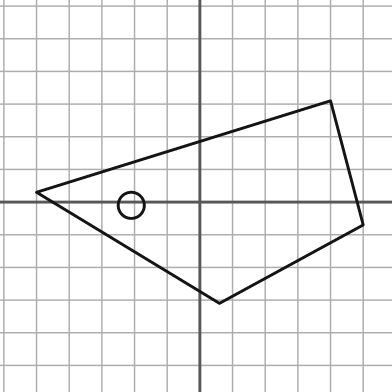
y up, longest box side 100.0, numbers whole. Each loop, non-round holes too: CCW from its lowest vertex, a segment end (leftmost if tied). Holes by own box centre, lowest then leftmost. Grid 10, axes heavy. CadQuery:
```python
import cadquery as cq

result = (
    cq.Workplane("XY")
    .moveTo(6.0, -31.0)
    .lineTo(50.0, -7.0)
    .lineTo(40.0, 31.0)
    .lineTo(-50.0, 3.0)
    .close()
    .moveTo(-21.0, -1.0)
    .circle(4.0)
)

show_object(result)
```